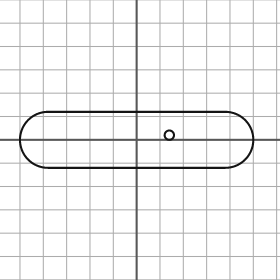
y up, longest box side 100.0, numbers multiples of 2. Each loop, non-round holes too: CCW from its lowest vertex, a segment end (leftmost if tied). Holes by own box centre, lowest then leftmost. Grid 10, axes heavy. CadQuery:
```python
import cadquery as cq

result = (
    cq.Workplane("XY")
    .moveTo(-38.0, -12.0)
    .lineTo(38.0, -12.0)
    .threePointArc((50.0, 0.0), (38.0, 12.0))
    .lineTo(-38.0, 12.0)
    .threePointArc((-50.0, 0.0), (-38.0, -12.0))
    .close()
    .moveTo(14.0, 2.0)
    .circle(2.0)
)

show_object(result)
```